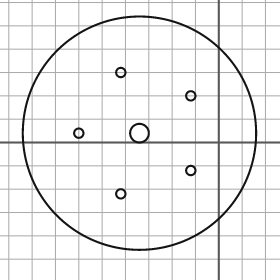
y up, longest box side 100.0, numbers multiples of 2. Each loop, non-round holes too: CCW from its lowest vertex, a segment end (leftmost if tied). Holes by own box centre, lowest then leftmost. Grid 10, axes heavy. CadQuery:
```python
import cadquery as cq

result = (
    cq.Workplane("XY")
    .moveTo(-34.0, 4.0)
    .circle(50.0)
    .moveTo(-42.0, -22.0)
    .circle(2.0)
    .moveTo(-12.0, -12.0)
    .circle(2.0)
    .moveTo(-60.0, 4.0)
    .circle(2.0)
    .moveTo(-34.0, 4.0)
    .circle(4.0)
    .moveTo(-12.0, 20.0)
    .circle(2.0)
    .moveTo(-42.0, 30.0)
    .circle(2.0)
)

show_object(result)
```